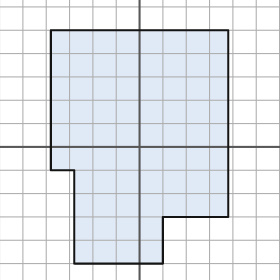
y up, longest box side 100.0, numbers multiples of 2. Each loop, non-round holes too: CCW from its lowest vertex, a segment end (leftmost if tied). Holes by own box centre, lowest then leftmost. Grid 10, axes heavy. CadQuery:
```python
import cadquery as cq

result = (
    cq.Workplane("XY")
    .moveTo(-28.0, -50.0)
    .lineTo(10.0, -50.0)
    .lineTo(10.0, -30.0)
    .lineTo(38.0, -30.0)
    .lineTo(38.0, 50.0)
    .lineTo(-38.0, 50.0)
    .lineTo(-38.0, -10.0)
    .lineTo(-28.0, -10.0)
    .close()
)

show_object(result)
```